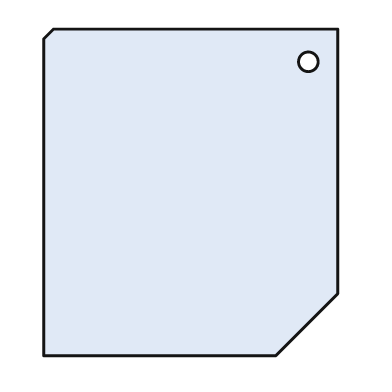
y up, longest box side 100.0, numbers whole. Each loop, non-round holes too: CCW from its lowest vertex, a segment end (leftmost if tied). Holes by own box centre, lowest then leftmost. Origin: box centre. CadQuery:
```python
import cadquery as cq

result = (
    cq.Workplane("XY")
    .moveTo(-45.0, -50.0)
    .lineTo(26.0, -50.0)
    .lineTo(45.0, -31.0)
    .lineTo(45.0, 50.0)
    .lineTo(-42.0, 50.0)
    .lineTo(-45.0, 47.0)
    .close()
    .moveTo(36.0, 40.0)
    .circle(3.0)
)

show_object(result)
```